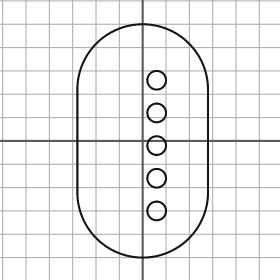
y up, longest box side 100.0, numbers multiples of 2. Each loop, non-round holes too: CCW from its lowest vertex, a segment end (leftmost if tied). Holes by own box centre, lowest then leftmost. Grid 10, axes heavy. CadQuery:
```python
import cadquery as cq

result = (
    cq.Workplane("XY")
    .moveTo(-28.0, -22.0)
    .threePointArc((0.0, -50.0), (28.0, -22.0))
    .lineTo(28.0, 22.0)
    .threePointArc((0.0, 50.0), (-28.0, 22.0))
    .close()
    .moveTo(6.0, -30.0)
    .circle(4.0)
    .moveTo(6.0, -16.0)
    .circle(4.0)
    .moveTo(6.0, -2.0)
    .circle(4.0)
    .moveTo(6.0, 12.0)
    .circle(4.0)
    .moveTo(6.0, 26.0)
    .circle(4.0)
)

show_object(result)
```